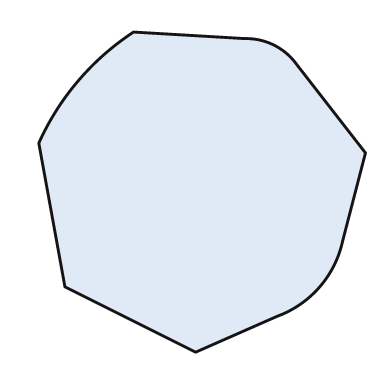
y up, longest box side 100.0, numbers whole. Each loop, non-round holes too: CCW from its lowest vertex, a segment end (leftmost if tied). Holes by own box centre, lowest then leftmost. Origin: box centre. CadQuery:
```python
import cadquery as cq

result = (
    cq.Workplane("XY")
    .moveTo(-2.0, -49.0)
    .lineTo(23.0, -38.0)
    .threePointArc((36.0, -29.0), (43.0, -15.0))
    .lineTo(50.0, 12.0)
    .lineTo(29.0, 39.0)
    .threePointArc((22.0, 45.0), (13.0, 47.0))
    .lineTo(-21.0, 49.0)
    .threePointArc((-38.0, 34.0), (-50.0, 15.0))
    .lineTo(-42.0, -29.0)
    .close()
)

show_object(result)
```